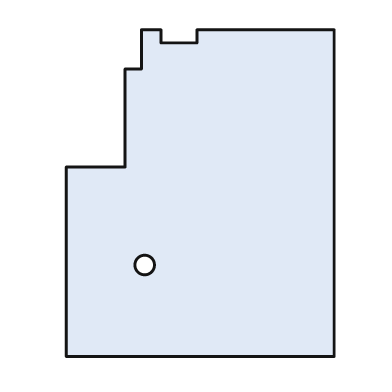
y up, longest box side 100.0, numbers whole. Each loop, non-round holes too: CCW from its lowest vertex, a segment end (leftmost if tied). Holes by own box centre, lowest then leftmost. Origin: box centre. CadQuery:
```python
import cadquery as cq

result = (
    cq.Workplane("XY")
    .moveTo(-41.0, -50.0)
    .lineTo(41.0, -50.0)
    .lineTo(41.0, 50.0)
    .lineTo(-1.0, 50.0)
    .lineTo(-1.0, 46.0)
    .lineTo(-12.0, 46.0)
    .lineTo(-12.0, 50.0)
    .lineTo(-18.0, 50.0)
    .lineTo(-18.0, 38.0)
    .lineTo(-23.0, 38.0)
    .lineTo(-23.0, 8.0)
    .lineTo(-41.0, 8.0)
    .close()
    .moveTo(-17.0, -22.0)
    .circle(3.0)
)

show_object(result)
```